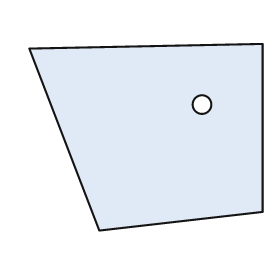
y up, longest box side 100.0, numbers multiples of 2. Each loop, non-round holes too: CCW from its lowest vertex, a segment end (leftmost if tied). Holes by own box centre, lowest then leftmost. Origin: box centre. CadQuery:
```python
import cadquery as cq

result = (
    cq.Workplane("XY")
    .moveTo(-20.0, -40.0)
    .lineTo(50.0, -32.0)
    .lineTo(50.0, 40.0)
    .lineTo(-50.0, 38.0)
    .close()
    .moveTo(24.0, 14.0)
    .circle(4.0)
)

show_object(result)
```